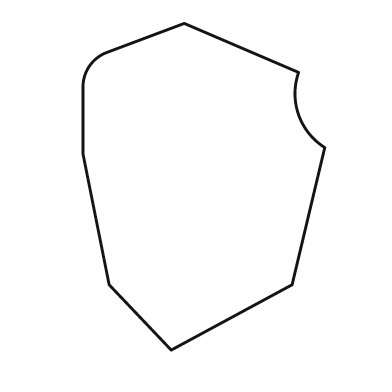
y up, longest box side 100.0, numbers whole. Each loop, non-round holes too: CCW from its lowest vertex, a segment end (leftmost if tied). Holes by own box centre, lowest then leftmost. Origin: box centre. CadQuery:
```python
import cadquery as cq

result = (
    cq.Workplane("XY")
    .moveTo(-10.0, -50.0)
    .lineTo(27.0, -30.0)
    .lineTo(37.0, 12.0)
    .threePointArc((29.0, 22.0), (29.0, 35.0))
    .lineTo(-6.0, 50.0)
    .lineTo(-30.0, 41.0)
    .threePointArc((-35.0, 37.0), (-37.0, 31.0))
    .lineTo(-37.0, 10.0)
    .lineTo(-29.0, -30.0)
    .close()
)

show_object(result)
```